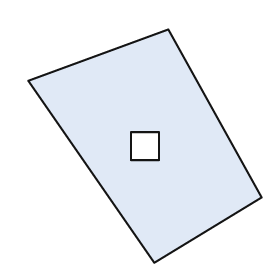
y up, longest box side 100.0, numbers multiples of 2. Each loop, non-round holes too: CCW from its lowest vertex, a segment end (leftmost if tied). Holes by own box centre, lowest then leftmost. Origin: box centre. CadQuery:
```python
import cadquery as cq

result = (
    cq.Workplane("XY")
    .moveTo(4.0, -50.0)
    .lineTo(50.0, -22.0)
    .lineTo(10.0, 50.0)
    .lineTo(-50.0, 28.0)
    .close()
    .moveTo(-6.0, -6.0)
    .lineTo(6.0, -6.0)
    .lineTo(6.0, 6.0)
    .lineTo(-6.0, 6.0)
    .close()
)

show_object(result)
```